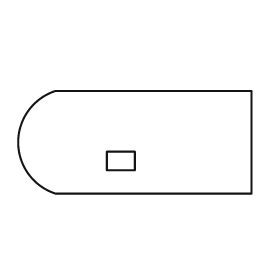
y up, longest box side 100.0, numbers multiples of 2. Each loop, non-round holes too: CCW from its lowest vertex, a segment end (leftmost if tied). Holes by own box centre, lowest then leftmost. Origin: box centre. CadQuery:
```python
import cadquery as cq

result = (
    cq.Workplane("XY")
    .moveTo(-34.0, -22.0)
    .lineTo(50.0, -22.0)
    .lineTo(50.0, 22.0)
    .lineTo(-34.0, 22.0)
    .threePointArc((-50.0, 0.0), (-34.0, -22.0))
    .close()
    .moveTo(-12.0, -12.0)
    .lineTo(0.0, -12.0)
    .lineTo(0.0, -4.0)
    .lineTo(-12.0, -4.0)
    .close()
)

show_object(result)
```